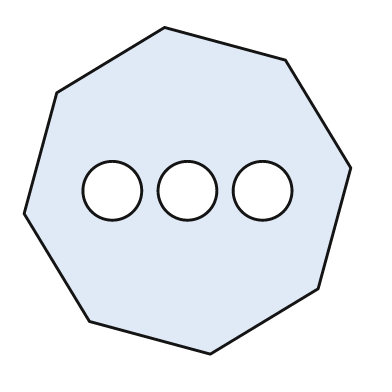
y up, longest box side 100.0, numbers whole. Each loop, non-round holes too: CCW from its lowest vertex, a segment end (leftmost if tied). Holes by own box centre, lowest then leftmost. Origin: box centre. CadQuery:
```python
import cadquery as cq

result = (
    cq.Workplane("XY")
    .moveTo(7.0, -50.0)
    .lineTo(40.0, -30.0)
    .lineTo(50.0, 7.0)
    .lineTo(30.0, 40.0)
    .lineTo(-7.0, 50.0)
    .lineTo(-40.0, 30.0)
    .lineTo(-50.0, -7.0)
    .lineTo(-30.0, -40.0)
    .close()
    .moveTo(-23.0, 0.0)
    .circle(9.0)
    .moveTo(0.0, 0.0)
    .circle(9.0)
    .moveTo(23.0, 0.0)
    .circle(9.0)
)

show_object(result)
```